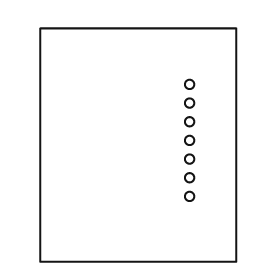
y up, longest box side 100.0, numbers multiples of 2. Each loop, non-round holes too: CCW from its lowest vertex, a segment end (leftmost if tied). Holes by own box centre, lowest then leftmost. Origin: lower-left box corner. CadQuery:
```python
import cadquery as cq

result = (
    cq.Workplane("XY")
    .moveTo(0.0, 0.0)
    .lineTo(84.0, 0.0)
    .lineTo(84.0, 100.0)
    .lineTo(0.0, 100.0)
    .close()
    .moveTo(64.0, 28.0)
    .circle(2.0)
    .moveTo(64.0, 36.0)
    .circle(2.0)
    .moveTo(64.0, 44.0)
    .circle(2.0)
    .moveTo(64.0, 52.0)
    .circle(2.0)
    .moveTo(64.0, 60.0)
    .circle(2.0)
    .moveTo(64.0, 68.0)
    .circle(2.0)
    .moveTo(64.0, 76.0)
    .circle(2.0)
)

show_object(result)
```